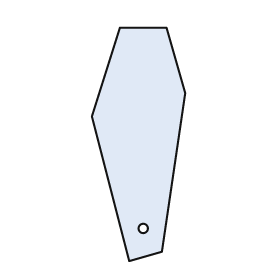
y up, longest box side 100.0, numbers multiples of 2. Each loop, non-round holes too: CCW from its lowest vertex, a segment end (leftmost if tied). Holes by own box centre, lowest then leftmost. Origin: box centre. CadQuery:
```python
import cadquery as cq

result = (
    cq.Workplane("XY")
    .moveTo(-4.0, -50.0)
    .lineTo(10.0, -46.0)
    .lineTo(20.0, 22.0)
    .lineTo(12.0, 50.0)
    .lineTo(-8.0, 50.0)
    .lineTo(-20.0, 12.0)
    .close()
    .moveTo(2.0, -36.0)
    .circle(2.0)
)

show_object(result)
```